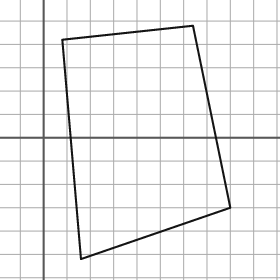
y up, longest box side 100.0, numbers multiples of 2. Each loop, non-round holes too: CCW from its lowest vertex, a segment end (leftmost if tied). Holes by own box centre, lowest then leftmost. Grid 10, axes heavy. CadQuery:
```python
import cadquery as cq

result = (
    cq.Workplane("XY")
    .moveTo(16.0, -52.0)
    .lineTo(80.0, -30.0)
    .lineTo(64.0, 48.0)
    .lineTo(8.0, 42.0)
    .close()
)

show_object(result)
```